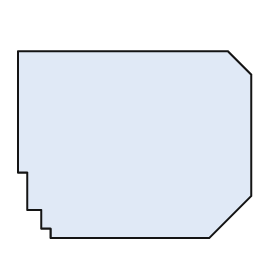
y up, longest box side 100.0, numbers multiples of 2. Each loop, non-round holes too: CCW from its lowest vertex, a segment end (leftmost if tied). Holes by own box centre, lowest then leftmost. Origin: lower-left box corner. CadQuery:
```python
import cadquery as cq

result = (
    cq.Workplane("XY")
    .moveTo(14.0, 0.0)
    .lineTo(82.0, 0.0)
    .lineTo(100.0, 18.0)
    .lineTo(100.0, 70.0)
    .lineTo(90.0, 80.0)
    .lineTo(0.0, 80.0)
    .lineTo(0.0, 28.0)
    .lineTo(4.0, 28.0)
    .lineTo(4.0, 12.0)
    .lineTo(10.0, 12.0)
    .lineTo(10.0, 4.0)
    .lineTo(14.0, 4.0)
    .close()
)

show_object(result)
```